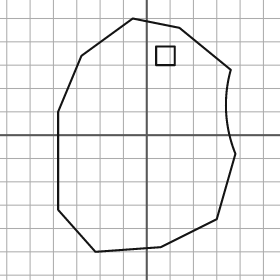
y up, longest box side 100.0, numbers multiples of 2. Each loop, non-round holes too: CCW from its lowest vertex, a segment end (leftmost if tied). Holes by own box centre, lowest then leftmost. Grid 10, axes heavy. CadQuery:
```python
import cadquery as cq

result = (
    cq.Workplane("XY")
    .moveTo(-22.0, -50.0)
    .lineTo(6.0, -48.0)
    .lineTo(30.0, -36.0)
    .lineTo(38.0, -8.0)
    .threePointArc((34.0, 10.0), (36.0, 28.0))
    .lineTo(14.0, 46.0)
    .lineTo(-6.0, 50.0)
    .lineTo(-28.0, 34.0)
    .lineTo(-38.0, 10.0)
    .lineTo(-38.0, -32.0)
    .close()
    .moveTo(4.0, 30.0)
    .lineTo(12.0, 30.0)
    .lineTo(12.0, 38.0)
    .lineTo(4.0, 38.0)
    .close()
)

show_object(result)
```